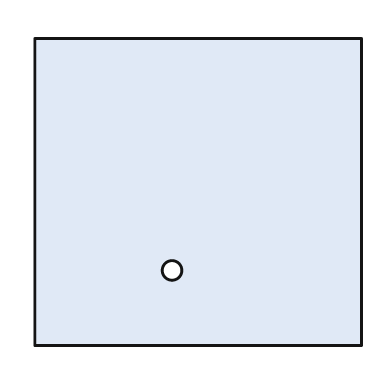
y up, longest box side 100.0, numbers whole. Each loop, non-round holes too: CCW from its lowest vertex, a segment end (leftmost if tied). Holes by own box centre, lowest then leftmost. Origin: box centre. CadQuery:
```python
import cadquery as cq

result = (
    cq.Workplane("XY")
    .moveTo(-50.0, -47.0)
    .lineTo(50.0, -47.0)
    .lineTo(50.0, 47.0)
    .lineTo(-50.0, 47.0)
    .close()
    .moveTo(-8.0, -24.0)
    .circle(3.0)
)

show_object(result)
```